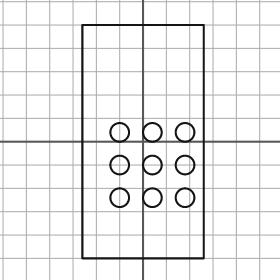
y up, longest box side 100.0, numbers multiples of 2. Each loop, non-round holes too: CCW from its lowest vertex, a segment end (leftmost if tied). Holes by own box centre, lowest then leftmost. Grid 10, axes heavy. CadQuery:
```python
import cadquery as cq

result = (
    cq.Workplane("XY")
    .moveTo(-26.0, -50.0)
    .lineTo(26.0, -50.0)
    .lineTo(26.0, 50.0)
    .lineTo(-26.0, 50.0)
    .close()
    .moveTo(-10.0, -24.0)
    .circle(4.0)
    .moveTo(4.0, -24.0)
    .circle(4.0)
    .moveTo(18.0, -24.0)
    .circle(4.0)
    .moveTo(-10.0, -10.0)
    .circle(4.0)
    .moveTo(4.0, -10.0)
    .circle(4.0)
    .moveTo(18.0, -10.0)
    .circle(4.0)
    .moveTo(-10.0, 4.0)
    .circle(4.0)
    .moveTo(4.0, 4.0)
    .circle(4.0)
    .moveTo(18.0, 4.0)
    .circle(4.0)
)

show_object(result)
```